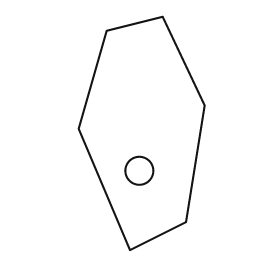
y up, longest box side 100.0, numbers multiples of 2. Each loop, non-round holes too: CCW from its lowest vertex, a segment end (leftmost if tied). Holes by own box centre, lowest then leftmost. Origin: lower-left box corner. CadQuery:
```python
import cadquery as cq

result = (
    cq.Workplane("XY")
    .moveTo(22.0, 0.0)
    .lineTo(46.0, 12.0)
    .lineTo(54.0, 62.0)
    .lineTo(36.0, 100.0)
    .lineTo(12.0, 94.0)
    .lineTo(0.0, 52.0)
    .close()
    .moveTo(26.0, 34.0)
    .circle(6.0)
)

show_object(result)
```